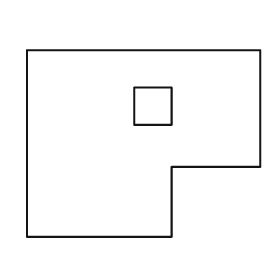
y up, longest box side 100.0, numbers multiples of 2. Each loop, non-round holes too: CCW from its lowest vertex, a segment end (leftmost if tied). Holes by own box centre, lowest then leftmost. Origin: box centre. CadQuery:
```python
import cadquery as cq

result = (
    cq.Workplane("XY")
    .moveTo(-50.0, -40.0)
    .lineTo(12.0, -40.0)
    .lineTo(12.0, -10.0)
    .lineTo(50.0, -10.0)
    .lineTo(50.0, 40.0)
    .lineTo(-50.0, 40.0)
    .close()
    .moveTo(-4.0, 8.0)
    .lineTo(12.0, 8.0)
    .lineTo(12.0, 24.0)
    .lineTo(-4.0, 24.0)
    .close()
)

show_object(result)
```